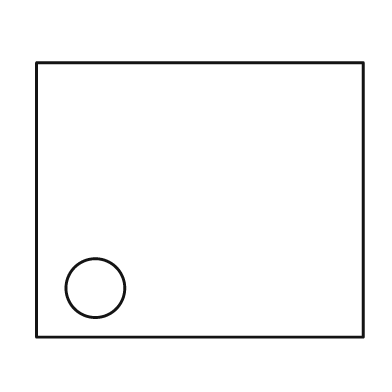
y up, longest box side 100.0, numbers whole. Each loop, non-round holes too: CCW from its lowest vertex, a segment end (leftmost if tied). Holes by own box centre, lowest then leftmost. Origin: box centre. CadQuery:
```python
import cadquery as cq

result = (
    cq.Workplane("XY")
    .moveTo(-50.0, -42.0)
    .lineTo(50.0, -42.0)
    .lineTo(50.0, 42.0)
    .lineTo(-50.0, 42.0)
    .close()
    .moveTo(-32.0, -27.0)
    .circle(9.0)
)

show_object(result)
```